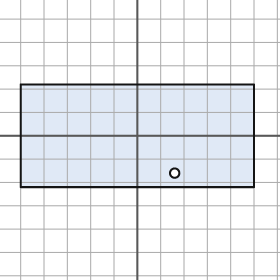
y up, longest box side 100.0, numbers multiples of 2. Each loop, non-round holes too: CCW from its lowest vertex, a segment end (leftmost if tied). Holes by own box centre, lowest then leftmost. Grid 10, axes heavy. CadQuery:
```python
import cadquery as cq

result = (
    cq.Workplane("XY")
    .moveTo(-50.0, -22.0)
    .lineTo(50.0, -22.0)
    .lineTo(50.0, 22.0)
    .lineTo(-50.0, 22.0)
    .close()
    .moveTo(16.0, -16.0)
    .circle(2.0)
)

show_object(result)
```